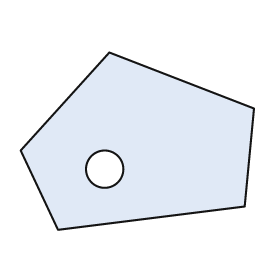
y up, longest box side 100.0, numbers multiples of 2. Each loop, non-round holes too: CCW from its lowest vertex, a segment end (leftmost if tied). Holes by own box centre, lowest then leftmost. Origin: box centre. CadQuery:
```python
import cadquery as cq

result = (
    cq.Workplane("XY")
    .moveTo(-34.0, -38.0)
    .lineTo(46.0, -28.0)
    .lineTo(50.0, 14.0)
    .lineTo(-12.0, 38.0)
    .lineTo(-50.0, -4.0)
    .close()
    .moveTo(-14.0, -12.0)
    .circle(8.0)
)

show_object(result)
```